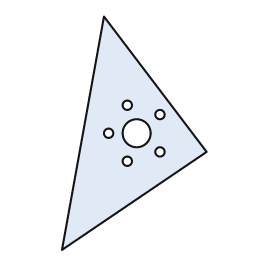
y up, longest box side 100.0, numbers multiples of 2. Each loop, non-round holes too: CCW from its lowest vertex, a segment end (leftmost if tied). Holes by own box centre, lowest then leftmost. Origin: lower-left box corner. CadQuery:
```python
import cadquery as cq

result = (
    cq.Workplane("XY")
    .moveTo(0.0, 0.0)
    .lineTo(62.0, 42.0)
    .lineTo(18.0, 100.0)
    .close()
    .moveTo(28.0, 38.0)
    .circle(2.0)
    .moveTo(42.0, 42.0)
    .circle(2.0)
    .moveTo(20.0, 50.0)
    .circle(2.0)
    .moveTo(32.0, 50.0)
    .circle(6.0)
    .moveTo(42.0, 58.0)
    .circle(2.0)
    .moveTo(28.0, 62.0)
    .circle(2.0)
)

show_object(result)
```